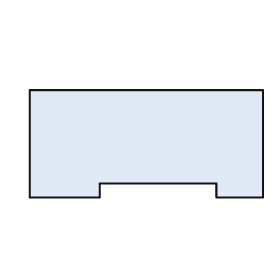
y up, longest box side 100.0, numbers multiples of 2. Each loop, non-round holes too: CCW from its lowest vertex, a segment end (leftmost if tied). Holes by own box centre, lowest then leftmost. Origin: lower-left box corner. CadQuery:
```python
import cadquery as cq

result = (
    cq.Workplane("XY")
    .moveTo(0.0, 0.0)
    .lineTo(30.0, 0.0)
    .lineTo(30.0, 6.0)
    .lineTo(80.0, 6.0)
    .lineTo(80.0, 0.0)
    .lineTo(100.0, 0.0)
    .lineTo(100.0, 46.0)
    .lineTo(0.0, 46.0)
    .close()
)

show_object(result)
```